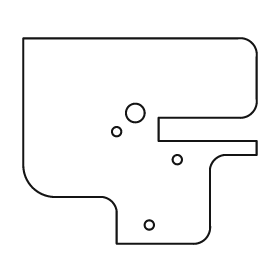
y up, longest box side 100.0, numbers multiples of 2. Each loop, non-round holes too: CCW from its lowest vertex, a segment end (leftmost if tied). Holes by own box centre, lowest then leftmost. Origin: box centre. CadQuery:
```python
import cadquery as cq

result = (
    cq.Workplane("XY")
    .moveTo(-10.0, -44.0)
    .lineTo(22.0, -44.0)
    .threePointArc((28.0, -42.0), (30.0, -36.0))
    .lineTo(30.0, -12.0)
    .threePointArc((32.0, -8.0), (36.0, -6.0))
    .lineTo(50.0, -6.0)
    .lineTo(50.0, 0.0)
    .lineTo(8.0, 0.0)
    .lineTo(8.0, 10.0)
    .lineTo(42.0, 10.0)
    .threePointArc((48.0, 12.0), (50.0, 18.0))
    .lineTo(50.0, 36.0)
    .threePointArc((48.0, 42.0), (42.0, 44.0))
    .lineTo(-50.0, 44.0)
    .lineTo(-50.0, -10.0)
    .threePointArc((-46.0, -20.0), (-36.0, -24.0))
    .lineTo(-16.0, -24.0)
    .threePointArc((-12.0, -26.0), (-10.0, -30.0))
    .close()
    .moveTo(4.0, -36.0)
    .circle(2.0)
    .moveTo(16.0, -8.0)
    .circle(2.0)
    .moveTo(-10.0, 4.0)
    .circle(2.0)
    .moveTo(-2.0, 12.0)
    .circle(4.0)
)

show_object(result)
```